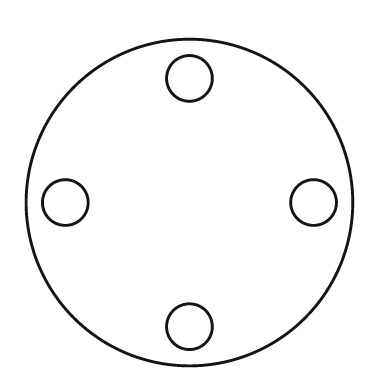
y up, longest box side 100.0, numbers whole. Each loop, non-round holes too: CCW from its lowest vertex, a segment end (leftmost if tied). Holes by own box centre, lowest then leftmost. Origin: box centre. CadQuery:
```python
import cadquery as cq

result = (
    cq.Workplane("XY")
    .moveTo(0.0, 0.0)
    .circle(50.0)
    .moveTo(0.0, -38.0)
    .circle(7.0)
    .moveTo(-38.0, 0.0)
    .circle(7.0)
    .moveTo(38.0, 0.0)
    .circle(7.0)
    .moveTo(0.0, 38.0)
    .circle(7.0)
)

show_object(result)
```